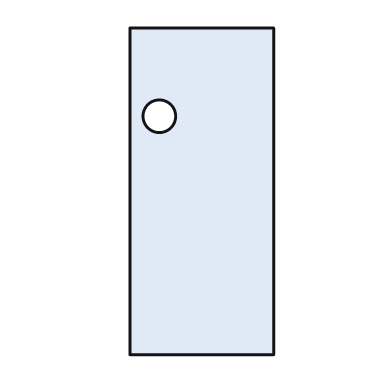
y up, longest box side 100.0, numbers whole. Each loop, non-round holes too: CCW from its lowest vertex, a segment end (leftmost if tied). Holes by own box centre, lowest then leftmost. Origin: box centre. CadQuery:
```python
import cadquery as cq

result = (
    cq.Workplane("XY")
    .moveTo(-22.0, -50.0)
    .lineTo(22.0, -50.0)
    .lineTo(22.0, 50.0)
    .lineTo(-22.0, 50.0)
    .close()
    .moveTo(-13.0, 23.0)
    .circle(5.0)
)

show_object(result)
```